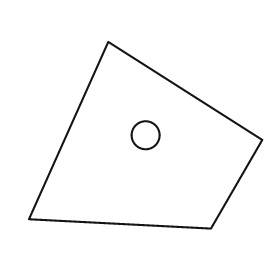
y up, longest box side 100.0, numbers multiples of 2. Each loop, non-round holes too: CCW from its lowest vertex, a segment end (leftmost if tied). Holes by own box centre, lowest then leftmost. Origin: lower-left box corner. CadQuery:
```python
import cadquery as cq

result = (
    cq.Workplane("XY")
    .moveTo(78.0, 0.0)
    .lineTo(100.0, 38.0)
    .lineTo(34.0, 80.0)
    .lineTo(0.0, 4.0)
    .close()
    .moveTo(50.0, 40.0)
    .circle(6.0)
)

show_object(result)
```